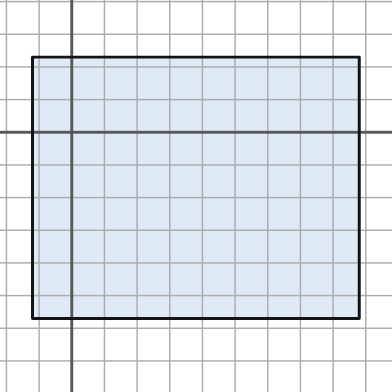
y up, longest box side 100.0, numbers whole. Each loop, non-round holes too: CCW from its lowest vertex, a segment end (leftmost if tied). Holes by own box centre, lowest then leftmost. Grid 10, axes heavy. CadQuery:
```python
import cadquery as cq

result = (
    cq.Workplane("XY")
    .moveTo(-12.0, -57.0)
    .lineTo(88.0, -57.0)
    .lineTo(88.0, 23.0)
    .lineTo(-12.0, 23.0)
    .close()
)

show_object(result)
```